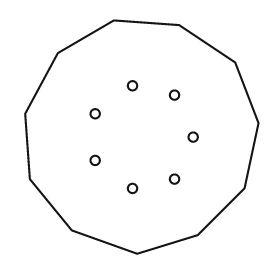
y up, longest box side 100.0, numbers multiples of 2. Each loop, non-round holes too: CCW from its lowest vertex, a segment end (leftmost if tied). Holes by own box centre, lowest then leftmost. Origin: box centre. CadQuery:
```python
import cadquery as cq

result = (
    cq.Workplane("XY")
    .moveTo(-2.0, -50.0)
    .lineTo(24.0, -42.0)
    .lineTo(44.0, -22.0)
    .lineTo(50.0, 6.0)
    .lineTo(40.0, 32.0)
    .lineTo(16.0, 48.0)
    .lineTo(-12.0, 50.0)
    .lineTo(-36.0, 36.0)
    .lineTo(-50.0, 10.0)
    .lineTo(-48.0, -18.0)
    .lineTo(-30.0, -40.0)
    .close()
    .moveTo(-4.0, -22.0)
    .circle(2.0)
    .moveTo(14.0, -18.0)
    .circle(2.0)
    .moveTo(-20.0, -10.0)
    .circle(2.0)
    .moveTo(22.0, 0.0)
    .circle(2.0)
    .moveTo(-20.0, 10.0)
    .circle(2.0)
    .moveTo(14.0, 18.0)
    .circle(2.0)
    .moveTo(-4.0, 22.0)
    .circle(2.0)
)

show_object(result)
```